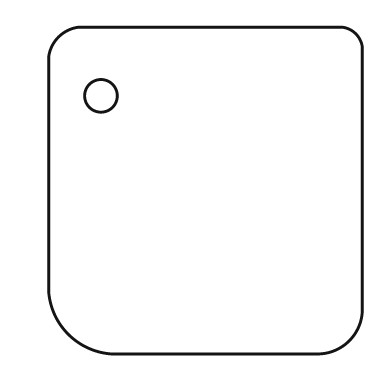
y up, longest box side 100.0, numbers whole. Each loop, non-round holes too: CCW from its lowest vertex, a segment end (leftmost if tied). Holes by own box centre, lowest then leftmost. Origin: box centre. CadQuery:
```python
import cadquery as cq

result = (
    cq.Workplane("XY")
    .moveTo(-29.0, -50.0)
    .lineTo(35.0, -50.0)
    .threePointArc((44.0, -46.0), (48.0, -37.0))
    .lineTo(48.0, 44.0)
    .threePointArc((46.0, 48.0), (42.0, 50.0))
    .lineTo(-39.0, 50.0)
    .threePointArc((-45.0, 47.0), (-48.0, 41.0))
    .lineTo(-48.0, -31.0)
    .threePointArc((-42.0, -44.0), (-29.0, -50.0))
    .close()
    .moveTo(-32.0, 29.0)
    .circle(5.0)
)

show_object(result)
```